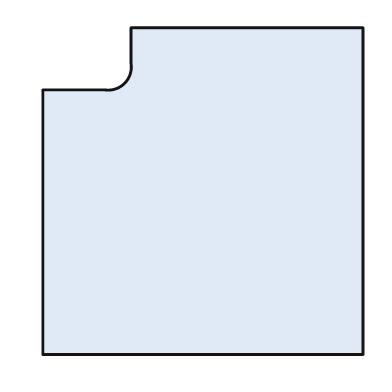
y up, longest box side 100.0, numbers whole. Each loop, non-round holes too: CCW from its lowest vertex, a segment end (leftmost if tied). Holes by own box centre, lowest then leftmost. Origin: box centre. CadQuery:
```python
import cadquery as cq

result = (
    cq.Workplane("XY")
    .moveTo(-49.0, -50.0)
    .lineTo(49.0, -50.0)
    .lineTo(49.0, 50.0)
    .lineTo(-22.0, 50.0)
    .lineTo(-22.0, 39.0)
    .threePointArc((-24.0, 33.0), (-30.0, 31.0))
    .lineTo(-49.0, 31.0)
    .close()
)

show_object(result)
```